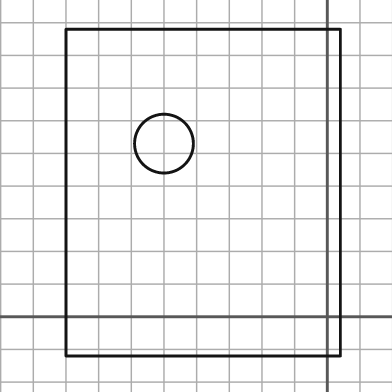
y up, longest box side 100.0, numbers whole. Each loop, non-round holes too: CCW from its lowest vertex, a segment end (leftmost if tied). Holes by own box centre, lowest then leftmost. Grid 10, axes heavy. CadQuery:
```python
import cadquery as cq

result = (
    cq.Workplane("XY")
    .moveTo(-80.0, -12.0)
    .lineTo(4.0, -12.0)
    .lineTo(4.0, 88.0)
    .lineTo(-80.0, 88.0)
    .close()
    .moveTo(-50.0, 53.0)
    .circle(9.0)
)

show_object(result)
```